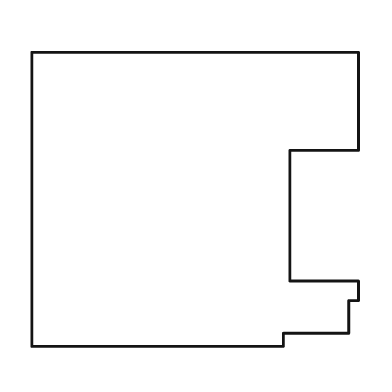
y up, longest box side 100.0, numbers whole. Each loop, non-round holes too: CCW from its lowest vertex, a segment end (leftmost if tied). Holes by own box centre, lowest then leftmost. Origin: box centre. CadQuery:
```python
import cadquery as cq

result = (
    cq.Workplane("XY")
    .moveTo(-50.0, -45.0)
    .lineTo(27.0, -45.0)
    .lineTo(27.0, -41.0)
    .lineTo(47.0, -41.0)
    .lineTo(47.0, -31.0)
    .lineTo(50.0, -31.0)
    .lineTo(50.0, -25.0)
    .lineTo(29.0, -25.0)
    .lineTo(29.0, 15.0)
    .lineTo(50.0, 15.0)
    .lineTo(50.0, 45.0)
    .lineTo(-50.0, 45.0)
    .close()
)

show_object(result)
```